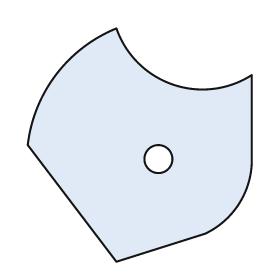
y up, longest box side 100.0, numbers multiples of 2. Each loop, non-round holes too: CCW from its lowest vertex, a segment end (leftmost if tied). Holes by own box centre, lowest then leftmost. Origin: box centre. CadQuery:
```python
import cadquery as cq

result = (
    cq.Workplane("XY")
    .moveTo(-10.0, -50.0)
    .lineTo(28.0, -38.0)
    .threePointArc((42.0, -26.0), (48.0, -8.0))
    .lineTo(48.0, 30.0)
    .threePointArc((14.0, 26.0), (-10.0, 50.0))
    .threePointArc((-36.0, 30.0), (-48.0, 0.0))
    .close()
    .moveTo(8.0, -6.0)
    .circle(6.0)
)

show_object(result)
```